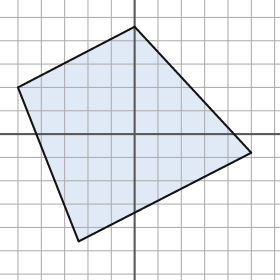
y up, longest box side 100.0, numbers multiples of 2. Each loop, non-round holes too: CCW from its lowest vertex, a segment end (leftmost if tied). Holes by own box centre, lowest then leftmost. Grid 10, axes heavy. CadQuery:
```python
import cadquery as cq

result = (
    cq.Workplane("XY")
    .moveTo(-24.0, -46.0)
    .lineTo(50.0, -8.0)
    .lineTo(0.0, 46.0)
    .lineTo(-50.0, 20.0)
    .close()
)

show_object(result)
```